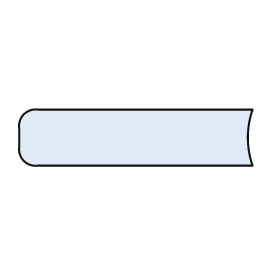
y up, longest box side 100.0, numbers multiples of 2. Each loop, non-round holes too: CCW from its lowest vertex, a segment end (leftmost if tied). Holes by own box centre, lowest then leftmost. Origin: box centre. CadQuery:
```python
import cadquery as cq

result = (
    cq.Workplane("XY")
    .moveTo(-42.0, -12.0)
    .lineTo(50.0, -12.0)
    .threePointArc((48.0, 0.0), (50.0, 12.0))
    .lineTo(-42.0, 12.0)
    .threePointArc((-48.0, 10.0), (-50.0, 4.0))
    .lineTo(-50.0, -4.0)
    .threePointArc((-48.0, -10.0), (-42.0, -12.0))
    .close()
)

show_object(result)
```